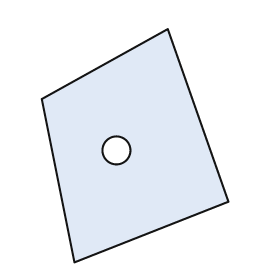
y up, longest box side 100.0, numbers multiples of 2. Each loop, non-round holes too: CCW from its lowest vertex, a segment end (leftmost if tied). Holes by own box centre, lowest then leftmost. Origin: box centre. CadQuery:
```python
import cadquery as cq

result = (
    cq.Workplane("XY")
    .moveTo(-26.0, -50.0)
    .lineTo(40.0, -24.0)
    .lineTo(14.0, 50.0)
    .lineTo(-40.0, 20.0)
    .close()
    .moveTo(-8.0, -2.0)
    .circle(6.0)
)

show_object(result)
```